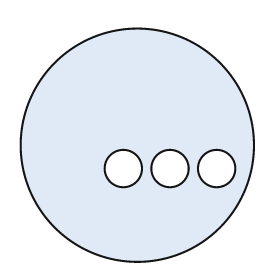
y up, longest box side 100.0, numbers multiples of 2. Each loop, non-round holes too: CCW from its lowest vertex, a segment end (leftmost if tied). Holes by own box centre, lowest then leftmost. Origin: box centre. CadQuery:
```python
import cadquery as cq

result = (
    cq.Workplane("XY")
    .moveTo(0.0, 0.0)
    .circle(50.0)
    .moveTo(-6.0, -10.0)
    .circle(8.0)
    .moveTo(14.0, -10.0)
    .circle(8.0)
    .moveTo(34.0, -10.0)
    .circle(8.0)
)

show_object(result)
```